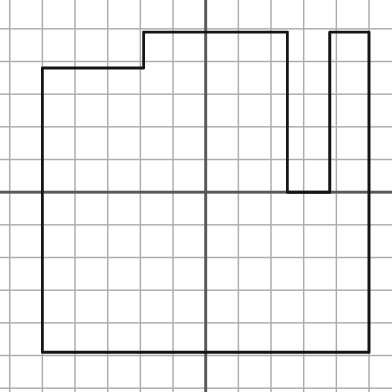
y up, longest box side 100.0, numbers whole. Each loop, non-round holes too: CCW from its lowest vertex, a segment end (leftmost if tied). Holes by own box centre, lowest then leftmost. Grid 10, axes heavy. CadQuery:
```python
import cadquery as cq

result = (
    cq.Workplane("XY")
    .moveTo(-50.0, -49.0)
    .lineTo(50.0, -49.0)
    .lineTo(50.0, 49.0)
    .lineTo(38.0, 49.0)
    .lineTo(38.0, 0.0)
    .lineTo(25.0, 0.0)
    .lineTo(25.0, 49.0)
    .lineTo(-19.0, 49.0)
    .lineTo(-19.0, 38.0)
    .lineTo(-50.0, 38.0)
    .close()
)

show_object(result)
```